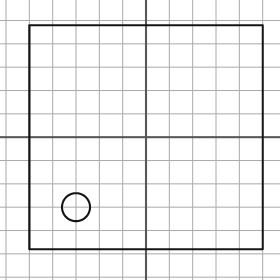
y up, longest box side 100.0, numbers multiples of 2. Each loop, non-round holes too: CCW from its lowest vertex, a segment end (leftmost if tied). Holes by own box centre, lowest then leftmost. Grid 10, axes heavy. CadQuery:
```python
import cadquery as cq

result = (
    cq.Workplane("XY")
    .moveTo(-50.0, -48.0)
    .lineTo(50.0, -48.0)
    .lineTo(50.0, 48.0)
    .lineTo(-50.0, 48.0)
    .close()
    .moveTo(-30.0, -30.0)
    .circle(6.0)
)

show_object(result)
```